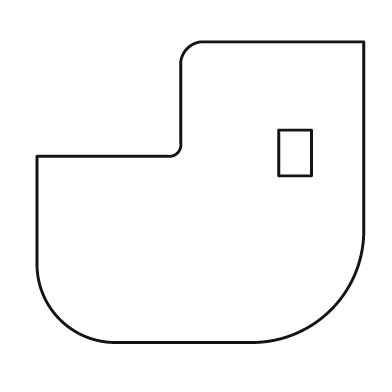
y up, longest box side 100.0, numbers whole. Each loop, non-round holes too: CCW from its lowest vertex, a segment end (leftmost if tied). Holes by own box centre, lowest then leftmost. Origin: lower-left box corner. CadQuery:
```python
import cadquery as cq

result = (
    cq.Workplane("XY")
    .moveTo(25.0, 0.0)
    .lineTo(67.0, 0.0)
    .threePointArc((90.0, 10.0), (100.0, 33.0))
    .lineTo(100.0, 92.0)
    .lineTo(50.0, 92.0)
    .threePointArc((46.0, 90.0), (44.0, 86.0))
    .lineTo(44.0, 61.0)
    .threePointArc((43.0, 58.0), (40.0, 57.0))
    .lineTo(0.0, 57.0)
    .lineTo(0.0, 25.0)
    .threePointArc((7.0, 7.0), (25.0, 0.0))
    .close()
    .moveTo(74.0, 51.0)
    .lineTo(84.0, 51.0)
    .lineTo(84.0, 65.0)
    .lineTo(74.0, 65.0)
    .close()
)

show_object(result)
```